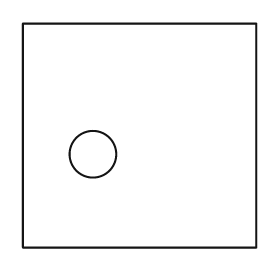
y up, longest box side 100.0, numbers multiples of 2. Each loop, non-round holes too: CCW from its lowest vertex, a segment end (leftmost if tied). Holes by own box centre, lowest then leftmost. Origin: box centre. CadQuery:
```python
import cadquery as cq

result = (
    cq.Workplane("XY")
    .moveTo(-50.0, -48.0)
    .lineTo(50.0, -48.0)
    .lineTo(50.0, 48.0)
    .lineTo(-50.0, 48.0)
    .close()
    .moveTo(-20.0, -8.0)
    .circle(10.0)
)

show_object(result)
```